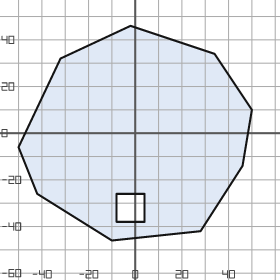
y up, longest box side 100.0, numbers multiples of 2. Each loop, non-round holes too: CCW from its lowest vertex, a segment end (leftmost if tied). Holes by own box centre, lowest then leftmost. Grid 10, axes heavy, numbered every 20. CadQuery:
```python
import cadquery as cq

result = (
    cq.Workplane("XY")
    .moveTo(-10.0, -46.0)
    .lineTo(28.0, -42.0)
    .lineTo(46.0, -14.0)
    .lineTo(50.0, 10.0)
    .lineTo(34.0, 34.0)
    .lineTo(-2.0, 46.0)
    .lineTo(-32.0, 32.0)
    .lineTo(-50.0, -6.0)
    .lineTo(-42.0, -26.0)
    .close()
    .moveTo(-8.0, -38.0)
    .lineTo(4.0, -38.0)
    .lineTo(4.0, -26.0)
    .lineTo(-8.0, -26.0)
    .close()
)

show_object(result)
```